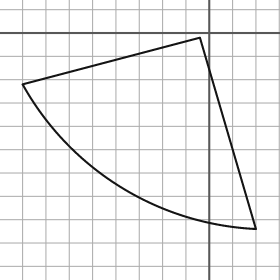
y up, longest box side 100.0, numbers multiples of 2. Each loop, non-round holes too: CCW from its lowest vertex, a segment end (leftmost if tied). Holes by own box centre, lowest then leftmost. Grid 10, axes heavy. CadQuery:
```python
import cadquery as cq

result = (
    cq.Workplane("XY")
    .moveTo(20.0, -84.0)
    .lineTo(-4.0, -2.0)
    .lineTo(-80.0, -22.0)
    .threePointArc((-38.0, -66.0), (20.0, -84.0))
    .close()
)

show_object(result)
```